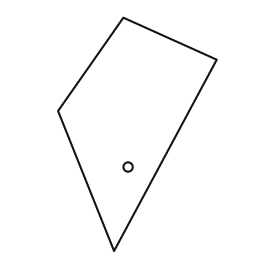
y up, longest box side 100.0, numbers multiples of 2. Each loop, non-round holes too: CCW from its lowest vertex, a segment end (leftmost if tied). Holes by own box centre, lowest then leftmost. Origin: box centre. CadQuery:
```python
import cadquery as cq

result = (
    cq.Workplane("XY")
    .moveTo(-10.0, -50.0)
    .lineTo(34.0, 32.0)
    .lineTo(-6.0, 50.0)
    .lineTo(-34.0, 10.0)
    .close()
    .moveTo(-4.0, -14.0)
    .circle(2.0)
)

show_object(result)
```